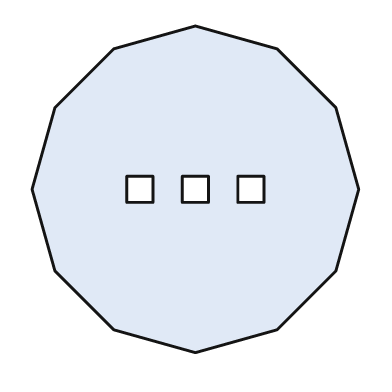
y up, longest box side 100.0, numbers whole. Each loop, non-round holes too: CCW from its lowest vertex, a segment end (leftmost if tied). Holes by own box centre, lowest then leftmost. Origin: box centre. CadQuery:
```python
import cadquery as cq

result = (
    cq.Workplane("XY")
    .moveTo(0.0, -50.0)
    .lineTo(25.0, -43.0)
    .lineTo(43.0, -25.0)
    .lineTo(50.0, 0.0)
    .lineTo(43.0, 25.0)
    .lineTo(25.0, 43.0)
    .lineTo(0.0, 50.0)
    .lineTo(-25.0, 43.0)
    .lineTo(-43.0, 25.0)
    .lineTo(-50.0, 0.0)
    .lineTo(-43.0, -25.0)
    .lineTo(-25.0, -43.0)
    .close()
    .moveTo(-21.0, -4.0)
    .lineTo(-13.0, -4.0)
    .lineTo(-13.0, 4.0)
    .lineTo(-21.0, 4.0)
    .close()
    .moveTo(-4.0, -4.0)
    .lineTo(4.0, -4.0)
    .lineTo(4.0, 4.0)
    .lineTo(-4.0, 4.0)
    .close()
    .moveTo(13.0, -4.0)
    .lineTo(21.0, -4.0)
    .lineTo(21.0, 4.0)
    .lineTo(13.0, 4.0)
    .close()
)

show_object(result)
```